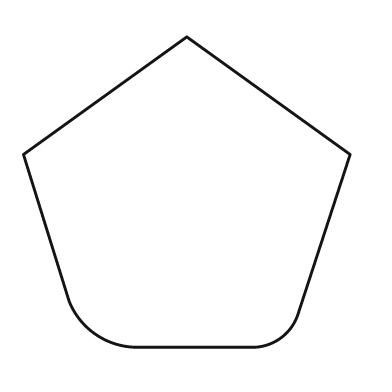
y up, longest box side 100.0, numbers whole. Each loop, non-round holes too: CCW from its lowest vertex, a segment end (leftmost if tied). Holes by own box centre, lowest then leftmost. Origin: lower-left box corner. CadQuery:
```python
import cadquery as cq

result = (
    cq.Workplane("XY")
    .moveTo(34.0, 0.0)
    .lineTo(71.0, 0.0)
    .threePointArc((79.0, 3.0), (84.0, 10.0))
    .lineTo(100.0, 59.0)
    .lineTo(50.0, 95.0)
    .lineTo(0.0, 59.0)
    .lineTo(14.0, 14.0)
    .threePointArc((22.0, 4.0), (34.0, 0.0))
    .close()
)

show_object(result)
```